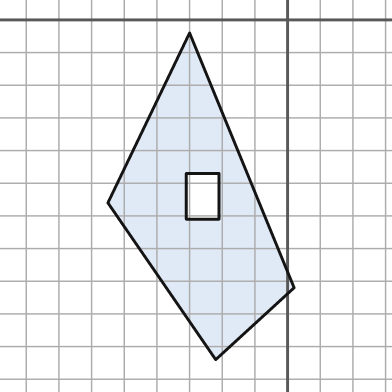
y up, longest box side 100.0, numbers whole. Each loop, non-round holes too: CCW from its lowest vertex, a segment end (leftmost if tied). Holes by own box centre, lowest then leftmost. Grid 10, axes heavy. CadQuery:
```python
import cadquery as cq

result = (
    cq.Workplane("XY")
    .moveTo(-22.0, -104.0)
    .lineTo(2.0, -82.0)
    .lineTo(-30.0, -4.0)
    .lineTo(-55.0, -56.0)
    .close()
    .moveTo(-31.0, -61.0)
    .lineTo(-21.0, -61.0)
    .lineTo(-21.0, -47.0)
    .lineTo(-31.0, -47.0)
    .close()
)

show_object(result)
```